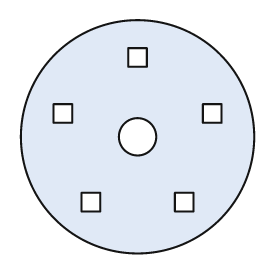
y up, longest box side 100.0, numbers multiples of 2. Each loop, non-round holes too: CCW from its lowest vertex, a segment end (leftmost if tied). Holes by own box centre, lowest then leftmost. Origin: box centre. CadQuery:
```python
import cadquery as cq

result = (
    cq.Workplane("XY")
    .moveTo(0.0, 0.0)
    .circle(50.0)
    .moveTo(-24.0, -32.0)
    .lineTo(-16.0, -32.0)
    .lineTo(-16.0, -24.0)
    .lineTo(-24.0, -24.0)
    .close()
    .moveTo(16.0, -32.0)
    .lineTo(24.0, -32.0)
    .lineTo(24.0, -24.0)
    .lineTo(16.0, -24.0)
    .close()
    .moveTo(0.0, 0.0)
    .circle(8.0)
    .moveTo(-36.0, 6.0)
    .lineTo(-28.0, 6.0)
    .lineTo(-28.0, 14.0)
    .lineTo(-36.0, 14.0)
    .close()
    .moveTo(28.0, 6.0)
    .lineTo(36.0, 6.0)
    .lineTo(36.0, 14.0)
    .lineTo(28.0, 14.0)
    .close()
    .moveTo(-4.0, 30.0)
    .lineTo(4.0, 30.0)
    .lineTo(4.0, 38.0)
    .lineTo(-4.0, 38.0)
    .close()
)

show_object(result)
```